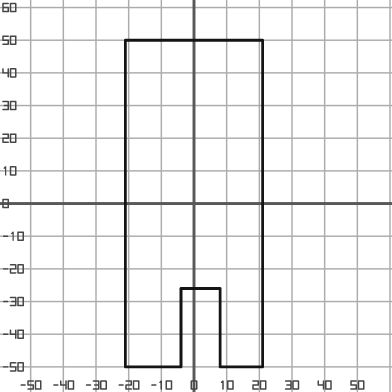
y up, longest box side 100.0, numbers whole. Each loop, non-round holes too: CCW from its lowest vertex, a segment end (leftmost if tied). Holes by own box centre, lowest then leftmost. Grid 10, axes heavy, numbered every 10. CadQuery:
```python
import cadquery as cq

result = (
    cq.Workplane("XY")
    .moveTo(-21.0, -50.0)
    .lineTo(-4.0, -50.0)
    .lineTo(-4.0, -26.0)
    .lineTo(8.0, -26.0)
    .lineTo(8.0, -50.0)
    .lineTo(21.0, -50.0)
    .lineTo(21.0, 50.0)
    .lineTo(-21.0, 50.0)
    .close()
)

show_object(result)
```